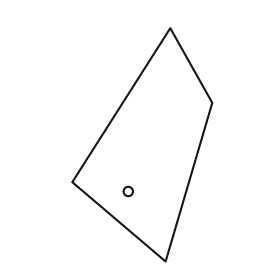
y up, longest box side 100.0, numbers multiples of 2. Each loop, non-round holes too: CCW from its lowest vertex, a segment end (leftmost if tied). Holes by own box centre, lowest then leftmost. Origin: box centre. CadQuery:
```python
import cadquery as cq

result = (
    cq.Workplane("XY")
    .moveTo(10.0, -50.0)
    .lineTo(30.0, 18.0)
    .lineTo(12.0, 50.0)
    .lineTo(-30.0, -16.0)
    .close()
    .moveTo(-6.0, -20.0)
    .circle(2.0)
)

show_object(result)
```